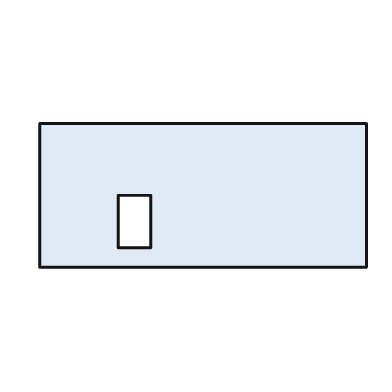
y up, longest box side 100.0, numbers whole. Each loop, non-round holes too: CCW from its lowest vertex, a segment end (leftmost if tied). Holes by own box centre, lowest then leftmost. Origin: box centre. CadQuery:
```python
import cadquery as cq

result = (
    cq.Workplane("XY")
    .moveTo(-50.0, -22.0)
    .lineTo(50.0, -22.0)
    .lineTo(50.0, 22.0)
    .lineTo(-50.0, 22.0)
    .close()
    .moveTo(-26.0, -16.0)
    .lineTo(-16.0, -16.0)
    .lineTo(-16.0, 0.0)
    .lineTo(-26.0, 0.0)
    .close()
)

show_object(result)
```